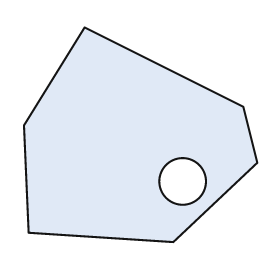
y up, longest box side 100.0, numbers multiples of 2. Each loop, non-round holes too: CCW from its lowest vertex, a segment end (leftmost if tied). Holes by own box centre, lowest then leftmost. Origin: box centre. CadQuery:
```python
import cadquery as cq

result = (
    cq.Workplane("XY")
    .moveTo(14.0, -46.0)
    .lineTo(50.0, -12.0)
    .lineTo(44.0, 12.0)
    .lineTo(-24.0, 46.0)
    .lineTo(-50.0, 4.0)
    .lineTo(-48.0, -42.0)
    .close()
    .moveTo(18.0, -20.0)
    .circle(10.0)
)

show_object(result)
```